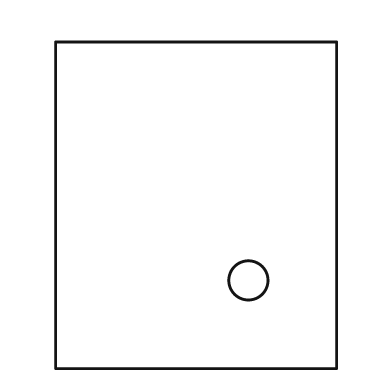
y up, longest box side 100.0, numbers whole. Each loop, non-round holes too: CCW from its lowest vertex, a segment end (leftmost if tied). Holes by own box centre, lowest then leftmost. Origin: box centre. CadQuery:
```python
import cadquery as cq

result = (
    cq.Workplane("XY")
    .moveTo(-43.0, -50.0)
    .lineTo(43.0, -50.0)
    .lineTo(43.0, 50.0)
    .lineTo(-43.0, 50.0)
    .close()
    .moveTo(16.0, -23.0)
    .circle(6.0)
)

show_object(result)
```